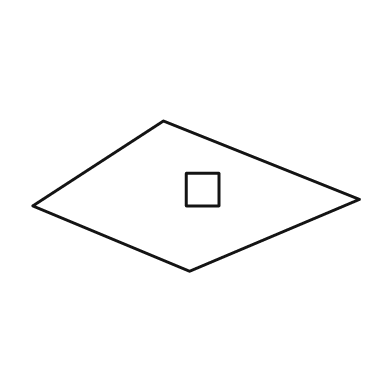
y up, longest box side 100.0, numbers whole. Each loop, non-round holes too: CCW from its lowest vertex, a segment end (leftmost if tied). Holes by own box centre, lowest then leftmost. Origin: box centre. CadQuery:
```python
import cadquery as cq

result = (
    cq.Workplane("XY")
    .moveTo(-2.0, -23.0)
    .lineTo(50.0, -1.0)
    .lineTo(-10.0, 23.0)
    .lineTo(-50.0, -3.0)
    .close()
    .moveTo(-3.0, -3.0)
    .lineTo(7.0, -3.0)
    .lineTo(7.0, 7.0)
    .lineTo(-3.0, 7.0)
    .close()
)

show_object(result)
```